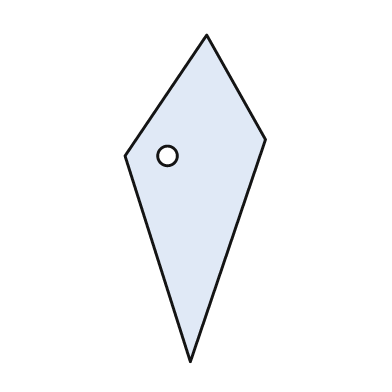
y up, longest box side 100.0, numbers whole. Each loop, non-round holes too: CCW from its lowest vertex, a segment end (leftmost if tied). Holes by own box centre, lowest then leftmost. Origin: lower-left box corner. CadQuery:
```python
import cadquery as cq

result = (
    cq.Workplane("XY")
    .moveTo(20.0, 0.0)
    .lineTo(43.0, 68.0)
    .lineTo(25.0, 100.0)
    .lineTo(0.0, 63.0)
    .close()
    .moveTo(13.0, 63.0)
    .circle(3.0)
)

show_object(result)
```